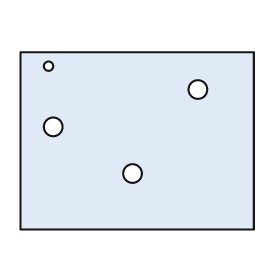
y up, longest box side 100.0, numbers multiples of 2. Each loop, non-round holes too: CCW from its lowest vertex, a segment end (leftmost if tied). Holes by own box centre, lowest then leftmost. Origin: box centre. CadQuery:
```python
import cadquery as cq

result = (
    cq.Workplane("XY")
    .moveTo(-50.0, -38.0)
    .lineTo(50.0, -38.0)
    .lineTo(50.0, 38.0)
    .lineTo(-50.0, 38.0)
    .close()
    .moveTo(-2.0, -14.0)
    .circle(4.0)
    .moveTo(-36.0, 6.0)
    .circle(4.0)
    .moveTo(26.0, 22.0)
    .circle(4.0)
    .moveTo(-38.0, 32.0)
    .circle(2.0)
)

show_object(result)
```